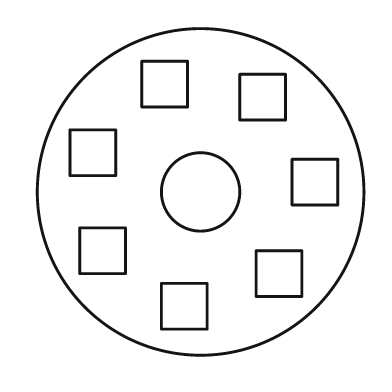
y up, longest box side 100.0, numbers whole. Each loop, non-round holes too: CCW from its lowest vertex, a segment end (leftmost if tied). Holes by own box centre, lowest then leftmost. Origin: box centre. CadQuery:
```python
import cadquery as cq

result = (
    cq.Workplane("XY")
    .moveTo(0.0, 0.0)
    .circle(50.0)
    .moveTo(-12.0, -42.0)
    .lineTo(2.0, -42.0)
    .lineTo(2.0, -28.0)
    .lineTo(-12.0, -28.0)
    .close()
    .moveTo(17.0, -32.0)
    .lineTo(31.0, -32.0)
    .lineTo(31.0, -18.0)
    .lineTo(17.0, -18.0)
    .close()
    .moveTo(-37.0, -25.0)
    .lineTo(-23.0, -25.0)
    .lineTo(-23.0, -11.0)
    .lineTo(-37.0, -11.0)
    .close()
    .moveTo(0.0, 0.0)
    .circle(12.0)
    .moveTo(28.0, -4.0)
    .lineTo(42.0, -4.0)
    .lineTo(42.0, 10.0)
    .lineTo(28.0, 10.0)
    .close()
    .moveTo(-40.0, 5.0)
    .lineTo(-26.0, 5.0)
    .lineTo(-26.0, 19.0)
    .lineTo(-40.0, 19.0)
    .close()
    .moveTo(12.0, 22.0)
    .lineTo(26.0, 22.0)
    .lineTo(26.0, 36.0)
    .lineTo(12.0, 36.0)
    .close()
    .moveTo(-18.0, 26.0)
    .lineTo(-4.0, 26.0)
    .lineTo(-4.0, 40.0)
    .lineTo(-18.0, 40.0)
    .close()
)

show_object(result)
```